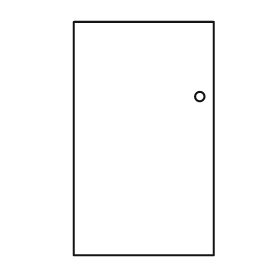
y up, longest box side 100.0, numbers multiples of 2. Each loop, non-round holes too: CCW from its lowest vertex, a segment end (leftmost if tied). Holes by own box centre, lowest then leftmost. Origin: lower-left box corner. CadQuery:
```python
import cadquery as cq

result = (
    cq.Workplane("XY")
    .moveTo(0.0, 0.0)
    .lineTo(60.0, 0.0)
    .lineTo(60.0, 100.0)
    .lineTo(0.0, 100.0)
    .close()
    .moveTo(54.0, 68.0)
    .circle(2.0)
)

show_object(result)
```